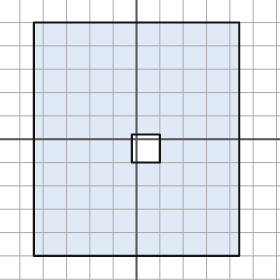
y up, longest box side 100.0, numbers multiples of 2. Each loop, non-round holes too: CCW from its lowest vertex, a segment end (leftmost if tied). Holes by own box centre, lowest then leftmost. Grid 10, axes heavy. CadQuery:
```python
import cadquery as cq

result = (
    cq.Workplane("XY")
    .moveTo(-44.0, -50.0)
    .lineTo(44.0, -50.0)
    .lineTo(44.0, 50.0)
    .lineTo(-44.0, 50.0)
    .close()
    .moveTo(-2.0, -10.0)
    .lineTo(10.0, -10.0)
    .lineTo(10.0, 2.0)
    .lineTo(-2.0, 2.0)
    .close()
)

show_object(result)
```